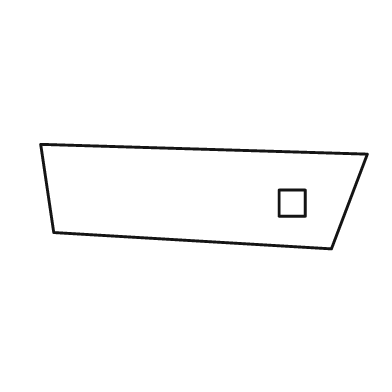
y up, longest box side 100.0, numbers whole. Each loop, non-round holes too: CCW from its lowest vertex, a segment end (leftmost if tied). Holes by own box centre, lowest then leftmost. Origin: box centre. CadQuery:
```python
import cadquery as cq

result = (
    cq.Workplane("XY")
    .moveTo(39.0, -16.0)
    .lineTo(50.0, 13.0)
    .lineTo(-50.0, 16.0)
    .lineTo(-46.0, -11.0)
    .close()
    .moveTo(23.0, -6.0)
    .lineTo(31.0, -6.0)
    .lineTo(31.0, 2.0)
    .lineTo(23.0, 2.0)
    .close()
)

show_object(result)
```